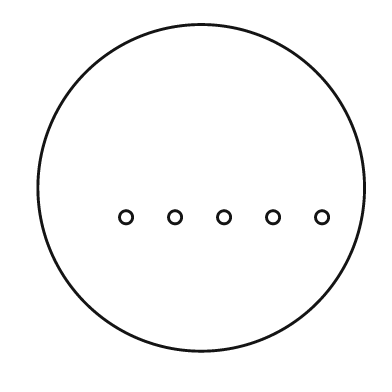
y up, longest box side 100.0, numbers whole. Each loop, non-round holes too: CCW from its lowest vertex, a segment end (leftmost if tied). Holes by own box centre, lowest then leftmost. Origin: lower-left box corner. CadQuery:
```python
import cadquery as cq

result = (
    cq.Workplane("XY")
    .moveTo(50.0, 50.0)
    .circle(50.0)
    .moveTo(27.0, 41.0)
    .circle(2.0)
    .moveTo(42.0, 41.0)
    .circle(2.0)
    .moveTo(57.0, 41.0)
    .circle(2.0)
    .moveTo(72.0, 41.0)
    .circle(2.0)
    .moveTo(87.0, 41.0)
    .circle(2.0)
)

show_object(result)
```